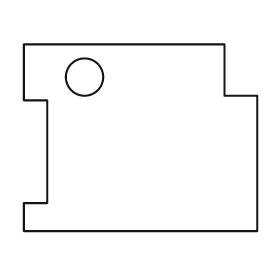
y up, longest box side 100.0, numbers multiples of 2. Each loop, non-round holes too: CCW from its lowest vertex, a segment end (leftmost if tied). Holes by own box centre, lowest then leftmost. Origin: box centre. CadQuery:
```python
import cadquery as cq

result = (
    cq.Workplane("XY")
    .moveTo(-50.0, -40.0)
    .lineTo(50.0, -40.0)
    .lineTo(50.0, 18.0)
    .lineTo(36.0, 18.0)
    .lineTo(36.0, 40.0)
    .lineTo(-50.0, 40.0)
    .lineTo(-50.0, 16.0)
    .lineTo(-40.0, 16.0)
    .lineTo(-40.0, -28.0)
    .lineTo(-50.0, -28.0)
    .close()
    .moveTo(-24.0, 26.0)
    .circle(8.0)
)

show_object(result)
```